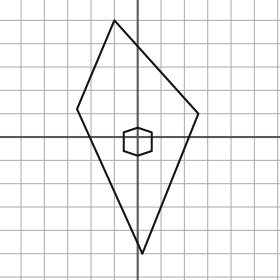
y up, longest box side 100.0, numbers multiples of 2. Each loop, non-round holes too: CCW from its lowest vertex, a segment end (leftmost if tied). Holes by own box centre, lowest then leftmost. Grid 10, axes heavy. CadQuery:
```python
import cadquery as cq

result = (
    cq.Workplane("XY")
    .moveTo(2.0, -50.0)
    .lineTo(26.0, 10.0)
    .lineTo(-10.0, 50.0)
    .lineTo(-26.0, 12.0)
    .close()
    .moveTo(0.0, -8.0)
    .lineTo(6.0, -6.0)
    .lineTo(6.0, 2.0)
    .lineTo(0.0, 4.0)
    .lineTo(-6.0, 2.0)
    .lineTo(-6.0, -6.0)
    .close()
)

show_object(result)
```